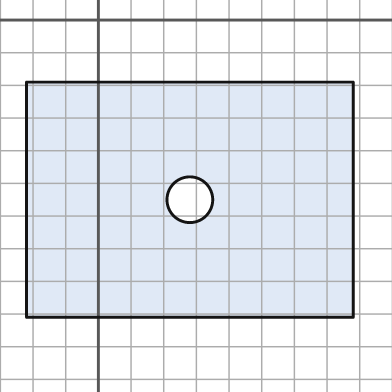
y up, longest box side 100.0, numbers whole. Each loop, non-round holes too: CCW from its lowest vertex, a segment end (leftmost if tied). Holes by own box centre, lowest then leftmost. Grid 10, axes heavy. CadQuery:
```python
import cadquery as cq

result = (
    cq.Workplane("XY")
    .moveTo(-22.0, -91.0)
    .lineTo(78.0, -91.0)
    .lineTo(78.0, -19.0)
    .lineTo(-22.0, -19.0)
    .close()
    .moveTo(28.0, -55.0)
    .circle(7.0)
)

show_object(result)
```